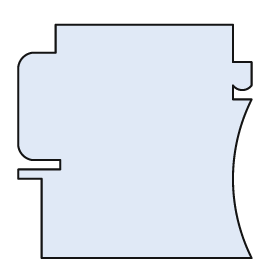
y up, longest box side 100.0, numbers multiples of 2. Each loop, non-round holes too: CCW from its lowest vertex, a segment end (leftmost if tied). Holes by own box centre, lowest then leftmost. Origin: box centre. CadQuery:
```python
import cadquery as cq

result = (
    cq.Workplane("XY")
    .moveTo(-40.0, -50.0)
    .lineTo(50.0, -50.0)
    .threePointArc((42.0, -16.0), (50.0, 18.0))
    .lineTo(42.0, 18.0)
    .lineTo(42.0, 24.0)
    .threePointArc((46.0, 22.0), (50.0, 24.0))
    .lineTo(50.0, 34.0)
    .lineTo(42.0, 34.0)
    .lineTo(42.0, 50.0)
    .lineTo(-34.0, 50.0)
    .lineTo(-34.0, 38.0)
    .lineTo(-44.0, 38.0)
    .threePointArc((-48.0, 36.0), (-50.0, 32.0))
    .lineTo(-50.0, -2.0)
    .threePointArc((-48.0, -6.0), (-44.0, -8.0))
    .lineTo(-32.0, -8.0)
    .lineTo(-32.0, -12.0)
    .lineTo(-50.0, -12.0)
    .lineTo(-50.0, -16.0)
    .lineTo(-40.0, -16.0)
    .close()
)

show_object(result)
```